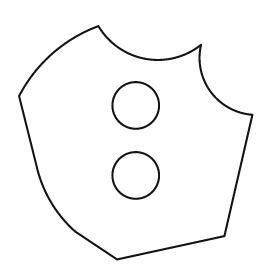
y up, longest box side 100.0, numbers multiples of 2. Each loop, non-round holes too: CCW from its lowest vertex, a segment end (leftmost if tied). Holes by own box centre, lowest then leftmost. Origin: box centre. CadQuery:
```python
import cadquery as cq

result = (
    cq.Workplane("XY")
    .moveTo(-8.0, -50.0)
    .lineTo(38.0, -40.0)
    .lineTo(50.0, 12.0)
    .threePointArc((32.0, 22.0), (28.0, 42.0))
    .threePointArc((4.0, 36.0), (-16.0, 50.0))
    .threePointArc((-36.0, 38.0), (-50.0, 20.0))
    .lineTo(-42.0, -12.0)
    .threePointArc((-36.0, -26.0), (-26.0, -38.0))
    .close()
    .moveTo(0.0, -14.0)
    .circle(10.0)
    .moveTo(0.0, 16.0)
    .circle(10.0)
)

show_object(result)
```